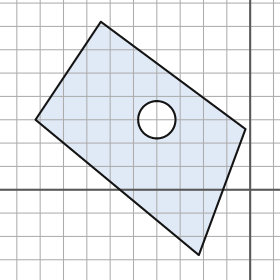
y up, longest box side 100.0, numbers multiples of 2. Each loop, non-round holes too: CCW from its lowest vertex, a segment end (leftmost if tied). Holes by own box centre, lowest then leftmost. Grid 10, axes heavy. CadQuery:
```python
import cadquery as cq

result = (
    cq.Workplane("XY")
    .moveTo(-22.0, -28.0)
    .lineTo(-2.0, 26.0)
    .lineTo(-64.0, 72.0)
    .lineTo(-92.0, 30.0)
    .close()
    .moveTo(-40.0, 30.0)
    .circle(8.0)
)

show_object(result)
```